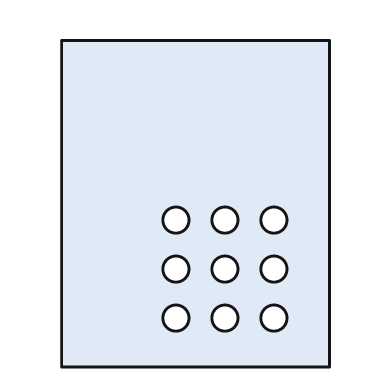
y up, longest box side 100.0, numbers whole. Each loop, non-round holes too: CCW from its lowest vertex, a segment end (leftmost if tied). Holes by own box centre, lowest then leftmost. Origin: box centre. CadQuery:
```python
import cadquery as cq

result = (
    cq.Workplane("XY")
    .moveTo(-41.0, -50.0)
    .lineTo(41.0, -50.0)
    .lineTo(41.0, 50.0)
    .lineTo(-41.0, 50.0)
    .close()
    .moveTo(-6.0, -35.0)
    .circle(4.0)
    .moveTo(9.0, -35.0)
    .circle(4.0)
    .moveTo(24.0, -35.0)
    .circle(4.0)
    .moveTo(-6.0, -20.0)
    .circle(4.0)
    .moveTo(9.0, -20.0)
    .circle(4.0)
    .moveTo(24.0, -20.0)
    .circle(4.0)
    .moveTo(-6.0, -5.0)
    .circle(4.0)
    .moveTo(9.0, -5.0)
    .circle(4.0)
    .moveTo(24.0, -5.0)
    .circle(4.0)
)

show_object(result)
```